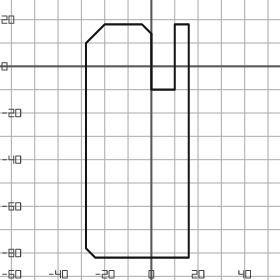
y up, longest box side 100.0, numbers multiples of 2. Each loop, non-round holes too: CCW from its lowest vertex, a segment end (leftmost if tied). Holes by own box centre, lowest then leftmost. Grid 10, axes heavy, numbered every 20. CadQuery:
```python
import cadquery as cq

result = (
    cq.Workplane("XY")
    .moveTo(-24.0, -82.0)
    .lineTo(16.0, -82.0)
    .lineTo(16.0, 18.0)
    .lineTo(10.0, 18.0)
    .lineTo(10.0, -10.0)
    .lineTo(0.0, -10.0)
    .lineTo(0.0, 14.0)
    .lineTo(-4.0, 18.0)
    .lineTo(-20.0, 18.0)
    .lineTo(-28.0, 10.0)
    .lineTo(-28.0, -78.0)
    .close()
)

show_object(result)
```